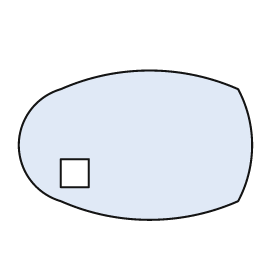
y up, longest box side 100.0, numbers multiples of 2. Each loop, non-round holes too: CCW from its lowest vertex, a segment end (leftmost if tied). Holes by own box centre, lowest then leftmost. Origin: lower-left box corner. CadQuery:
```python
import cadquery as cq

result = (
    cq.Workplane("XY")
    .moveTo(18.0, 8.0)
    .threePointArc((56.0, 0.0), (94.0, 8.0))
    .threePointArc((100.0, 32.0), (94.0, 56.0))
    .threePointArc((56.0, 64.0), (18.0, 56.0))
    .threePointArc((0.0, 32.0), (18.0, 8.0))
    .close()
    .moveTo(18.0, 14.0)
    .lineTo(30.0, 14.0)
    .lineTo(30.0, 26.0)
    .lineTo(18.0, 26.0)
    .close()
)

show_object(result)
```